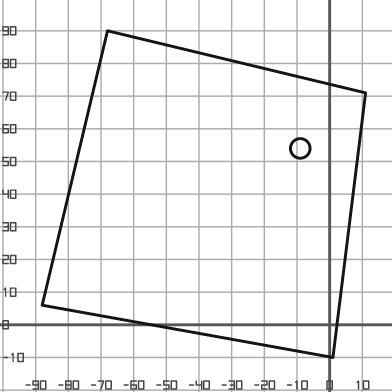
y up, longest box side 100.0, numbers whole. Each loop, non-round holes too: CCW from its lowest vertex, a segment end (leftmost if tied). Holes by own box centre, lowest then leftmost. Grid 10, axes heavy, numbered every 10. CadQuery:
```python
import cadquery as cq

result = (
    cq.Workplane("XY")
    .moveTo(1.0, -10.0)
    .lineTo(11.0, 71.0)
    .lineTo(-68.0, 90.0)
    .lineTo(-88.0, 6.0)
    .close()
    .moveTo(-9.0, 54.0)
    .circle(3.0)
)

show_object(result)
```